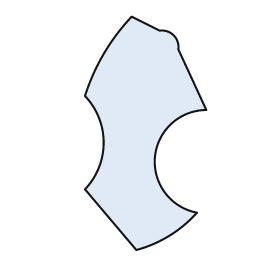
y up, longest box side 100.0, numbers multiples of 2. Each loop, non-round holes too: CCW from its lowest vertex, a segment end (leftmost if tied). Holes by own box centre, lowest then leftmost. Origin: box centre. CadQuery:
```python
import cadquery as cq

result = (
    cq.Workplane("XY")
    .moveTo(-4.0, -50.0)
    .threePointArc((10.0, -44.0), (22.0, -34.0))
    .threePointArc((4.0, -10.0), (26.0, 10.0))
    .lineTo(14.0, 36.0)
    .threePointArc((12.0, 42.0), (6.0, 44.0))
    .lineTo(-6.0, 50.0)
    .threePointArc((-18.0, 34.0), (-26.0, 16.0))
    .threePointArc((-18.0, -4.0), (-26.0, -24.0))
    .close()
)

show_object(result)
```